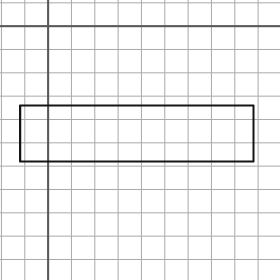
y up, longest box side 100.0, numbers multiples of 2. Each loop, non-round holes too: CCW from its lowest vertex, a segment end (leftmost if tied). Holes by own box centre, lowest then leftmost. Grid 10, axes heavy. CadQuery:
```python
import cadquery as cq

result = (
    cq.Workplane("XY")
    .moveTo(-12.0, -58.0)
    .lineTo(88.0, -58.0)
    .lineTo(88.0, -34.0)
    .lineTo(-12.0, -34.0)
    .close()
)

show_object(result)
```